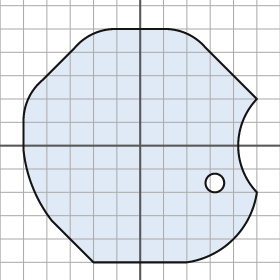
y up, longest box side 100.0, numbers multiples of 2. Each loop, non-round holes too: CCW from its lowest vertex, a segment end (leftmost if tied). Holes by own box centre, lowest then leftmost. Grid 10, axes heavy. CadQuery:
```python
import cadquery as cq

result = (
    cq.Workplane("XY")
    .moveTo(-20.0, -50.0)
    .lineTo(20.0, -50.0)
    .threePointArc((40.0, -40.0), (50.0, -20.0))
    .threePointArc((42.0, 0.0), (50.0, 20.0))
    .lineTo(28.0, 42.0)
    .threePointArc((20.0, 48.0), (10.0, 50.0))
    .lineTo(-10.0, 50.0)
    .threePointArc((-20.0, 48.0), (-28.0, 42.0))
    .lineTo(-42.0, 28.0)
    .threePointArc((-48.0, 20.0), (-50.0, 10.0))
    .lineTo(-50.0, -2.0)
    .threePointArc((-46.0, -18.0), (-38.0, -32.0))
    .close()
    .moveTo(32.0, -16.0)
    .circle(4.0)
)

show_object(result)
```